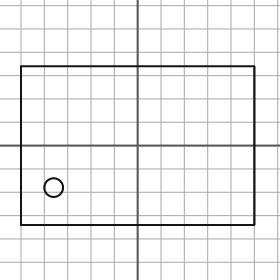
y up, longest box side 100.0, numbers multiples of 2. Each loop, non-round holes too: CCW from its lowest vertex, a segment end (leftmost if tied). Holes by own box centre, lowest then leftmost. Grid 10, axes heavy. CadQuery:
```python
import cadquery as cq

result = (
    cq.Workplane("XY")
    .moveTo(-50.0, -34.0)
    .lineTo(50.0, -34.0)
    .lineTo(50.0, 34.0)
    .lineTo(-50.0, 34.0)
    .close()
    .moveTo(-36.0, -18.0)
    .circle(4.0)
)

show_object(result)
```